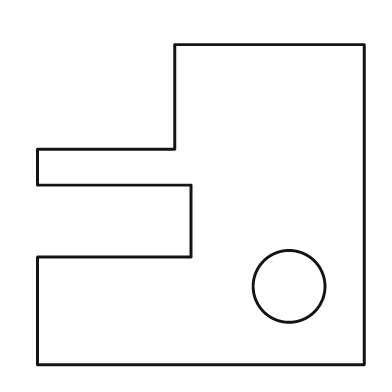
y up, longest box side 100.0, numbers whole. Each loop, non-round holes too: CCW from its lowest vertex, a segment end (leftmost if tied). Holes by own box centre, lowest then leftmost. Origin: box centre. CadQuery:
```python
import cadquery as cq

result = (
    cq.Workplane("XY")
    .moveTo(-50.0, -49.0)
    .lineTo(50.0, -49.0)
    .lineTo(50.0, 49.0)
    .lineTo(-8.0, 49.0)
    .lineTo(-8.0, 17.0)
    .lineTo(-50.0, 17.0)
    .lineTo(-50.0, 6.0)
    .lineTo(-3.0, 6.0)
    .lineTo(-3.0, -16.0)
    .lineTo(-50.0, -16.0)
    .close()
    .moveTo(27.0, -25.0)
    .circle(11.0)
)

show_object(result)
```